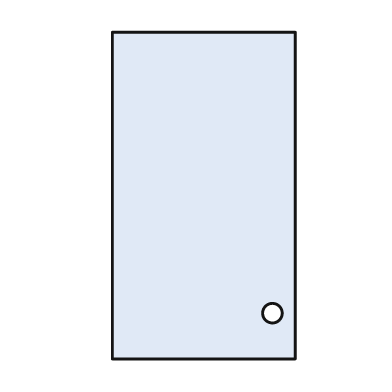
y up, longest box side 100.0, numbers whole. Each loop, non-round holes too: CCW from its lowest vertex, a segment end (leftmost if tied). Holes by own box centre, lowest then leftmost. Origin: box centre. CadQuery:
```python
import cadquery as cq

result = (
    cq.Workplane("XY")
    .moveTo(-28.0, -50.0)
    .lineTo(28.0, -50.0)
    .lineTo(28.0, 50.0)
    .lineTo(-28.0, 50.0)
    .close()
    .moveTo(21.0, -36.0)
    .circle(3.0)
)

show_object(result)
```